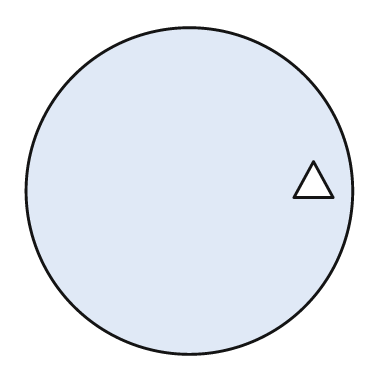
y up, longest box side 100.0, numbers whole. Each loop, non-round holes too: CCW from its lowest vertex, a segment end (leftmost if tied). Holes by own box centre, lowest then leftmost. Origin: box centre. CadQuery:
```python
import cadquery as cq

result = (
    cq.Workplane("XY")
    .moveTo(0.0, 0.0)
    .circle(50.0)
    .moveTo(32.0, -2.0)
    .lineTo(44.0, -2.0)
    .lineTo(38.0, 9.0)
    .close()
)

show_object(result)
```